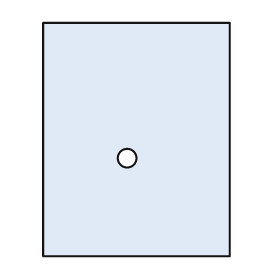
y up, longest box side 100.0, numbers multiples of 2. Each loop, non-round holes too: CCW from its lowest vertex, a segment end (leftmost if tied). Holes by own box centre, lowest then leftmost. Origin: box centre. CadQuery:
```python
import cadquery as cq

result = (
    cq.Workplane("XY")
    .moveTo(-40.0, -50.0)
    .lineTo(40.0, -50.0)
    .lineTo(40.0, 50.0)
    .lineTo(-40.0, 50.0)
    .close()
    .moveTo(-4.0, -8.0)
    .circle(4.0)
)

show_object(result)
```